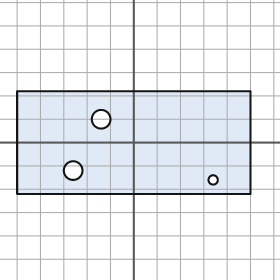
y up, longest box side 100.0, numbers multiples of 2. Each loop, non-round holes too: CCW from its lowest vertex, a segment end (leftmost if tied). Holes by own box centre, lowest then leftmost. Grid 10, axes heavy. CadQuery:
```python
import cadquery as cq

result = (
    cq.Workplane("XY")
    .moveTo(-50.0, -22.0)
    .lineTo(50.0, -22.0)
    .lineTo(50.0, 22.0)
    .lineTo(-50.0, 22.0)
    .close()
    .moveTo(34.0, -16.0)
    .circle(2.0)
    .moveTo(-26.0, -12.0)
    .circle(4.0)
    .moveTo(-14.0, 10.0)
    .circle(4.0)
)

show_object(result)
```